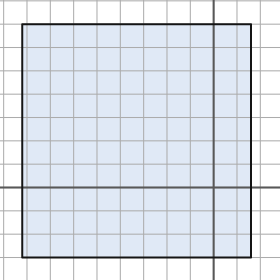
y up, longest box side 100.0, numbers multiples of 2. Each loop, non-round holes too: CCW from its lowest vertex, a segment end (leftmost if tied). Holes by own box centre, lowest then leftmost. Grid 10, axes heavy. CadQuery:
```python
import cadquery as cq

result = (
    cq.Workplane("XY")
    .moveTo(-82.0, -30.0)
    .lineTo(16.0, -30.0)
    .lineTo(16.0, 70.0)
    .lineTo(-82.0, 70.0)
    .close()
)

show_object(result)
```